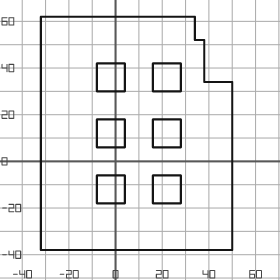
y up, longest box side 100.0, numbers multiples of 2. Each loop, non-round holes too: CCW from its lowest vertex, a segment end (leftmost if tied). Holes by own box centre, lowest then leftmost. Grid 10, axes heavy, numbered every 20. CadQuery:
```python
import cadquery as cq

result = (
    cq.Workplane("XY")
    .moveTo(-32.0, -38.0)
    .lineTo(50.0, -38.0)
    .lineTo(50.0, 34.0)
    .lineTo(38.0, 34.0)
    .lineTo(38.0, 52.0)
    .lineTo(34.0, 52.0)
    .lineTo(34.0, 62.0)
    .lineTo(-32.0, 62.0)
    .close()
    .moveTo(-8.0, -18.0)
    .lineTo(4.0, -18.0)
    .lineTo(4.0, -6.0)
    .lineTo(-8.0, -6.0)
    .close()
    .moveTo(16.0, -18.0)
    .lineTo(28.0, -18.0)
    .lineTo(28.0, -6.0)
    .lineTo(16.0, -6.0)
    .close()
    .moveTo(-8.0, 6.0)
    .lineTo(4.0, 6.0)
    .lineTo(4.0, 18.0)
    .lineTo(-8.0, 18.0)
    .close()
    .moveTo(16.0, 6.0)
    .lineTo(28.0, 6.0)
    .lineTo(28.0, 18.0)
    .lineTo(16.0, 18.0)
    .close()
    .moveTo(-8.0, 30.0)
    .lineTo(4.0, 30.0)
    .lineTo(4.0, 42.0)
    .lineTo(-8.0, 42.0)
    .close()
    .moveTo(16.0, 30.0)
    .lineTo(28.0, 30.0)
    .lineTo(28.0, 42.0)
    .lineTo(16.0, 42.0)
    .close()
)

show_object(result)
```